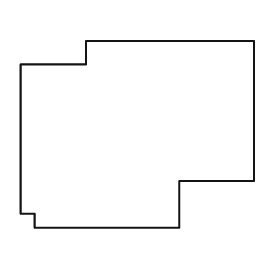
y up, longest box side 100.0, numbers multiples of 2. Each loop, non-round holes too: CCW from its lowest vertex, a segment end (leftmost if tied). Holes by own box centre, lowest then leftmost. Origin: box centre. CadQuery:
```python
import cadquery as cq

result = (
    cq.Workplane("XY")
    .moveTo(-44.0, -40.0)
    .lineTo(18.0, -40.0)
    .lineTo(18.0, -20.0)
    .lineTo(50.0, -20.0)
    .lineTo(50.0, 40.0)
    .lineTo(-22.0, 40.0)
    .lineTo(-22.0, 30.0)
    .lineTo(-50.0, 30.0)
    .lineTo(-50.0, -34.0)
    .lineTo(-44.0, -34.0)
    .close()
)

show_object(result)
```